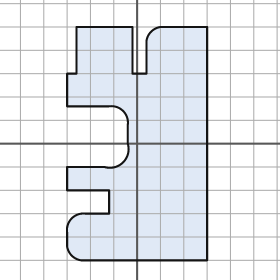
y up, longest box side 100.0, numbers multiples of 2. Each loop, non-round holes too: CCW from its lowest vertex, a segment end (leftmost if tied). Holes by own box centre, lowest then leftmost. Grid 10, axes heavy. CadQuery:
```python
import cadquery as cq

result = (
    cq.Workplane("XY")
    .moveTo(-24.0, -50.0)
    .lineTo(30.0, -50.0)
    .lineTo(30.0, 50.0)
    .lineTo(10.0, 50.0)
    .threePointArc((6.0, 48.0), (4.0, 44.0))
    .lineTo(4.0, 30.0)
    .lineTo(-2.0, 30.0)
    .lineTo(-2.0, 50.0)
    .lineTo(-26.0, 50.0)
    .lineTo(-26.0, 30.0)
    .lineTo(-30.0, 30.0)
    .lineTo(-30.0, 16.0)
    .lineTo(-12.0, 16.0)
    .threePointArc((-6.0, 14.0), (-4.0, 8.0))
    .lineTo(-4.0, 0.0)
    .threePointArc((-6.0, -8.0), (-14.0, -10.0))
    .lineTo(-30.0, -10.0)
    .lineTo(-30.0, -20.0)
    .lineTo(-12.0, -20.0)
    .lineTo(-12.0, -30.0)
    .lineTo(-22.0, -30.0)
    .threePointArc((-28.0, -32.0), (-30.0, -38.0))
    .lineTo(-30.0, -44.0)
    .threePointArc((-28.0, -48.0), (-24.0, -50.0))
    .close()
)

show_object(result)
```